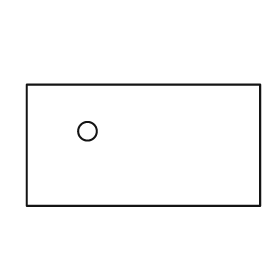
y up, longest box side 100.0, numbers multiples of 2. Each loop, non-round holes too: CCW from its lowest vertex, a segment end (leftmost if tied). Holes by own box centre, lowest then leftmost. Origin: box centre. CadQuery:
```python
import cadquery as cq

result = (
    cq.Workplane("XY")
    .moveTo(-50.0, -26.0)
    .lineTo(50.0, -26.0)
    .lineTo(50.0, 26.0)
    .lineTo(-50.0, 26.0)
    .close()
    .moveTo(-24.0, 6.0)
    .circle(4.0)
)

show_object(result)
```